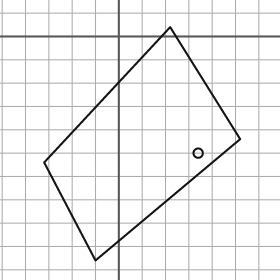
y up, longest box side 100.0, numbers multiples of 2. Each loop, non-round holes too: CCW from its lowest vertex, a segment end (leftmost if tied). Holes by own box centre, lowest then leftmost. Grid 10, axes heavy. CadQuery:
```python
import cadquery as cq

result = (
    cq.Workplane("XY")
    .moveTo(-10.0, -96.0)
    .lineTo(52.0, -44.0)
    .lineTo(22.0, 4.0)
    .lineTo(-32.0, -54.0)
    .close()
    .moveTo(34.0, -50.0)
    .circle(2.0)
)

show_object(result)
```